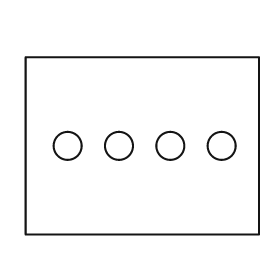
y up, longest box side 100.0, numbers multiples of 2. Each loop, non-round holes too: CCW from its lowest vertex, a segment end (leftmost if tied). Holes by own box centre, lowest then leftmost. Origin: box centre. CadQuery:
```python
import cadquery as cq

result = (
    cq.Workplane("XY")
    .moveTo(-50.0, -38.0)
    .lineTo(50.0, -38.0)
    .lineTo(50.0, 38.0)
    .lineTo(-50.0, 38.0)
    .close()
    .moveTo(-32.0, 0.0)
    .circle(6.0)
    .moveTo(-10.0, 0.0)
    .circle(6.0)
    .moveTo(12.0, 0.0)
    .circle(6.0)
    .moveTo(34.0, 0.0)
    .circle(6.0)
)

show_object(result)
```